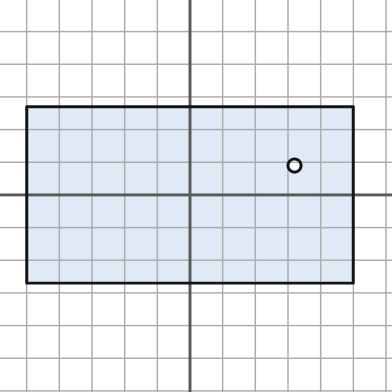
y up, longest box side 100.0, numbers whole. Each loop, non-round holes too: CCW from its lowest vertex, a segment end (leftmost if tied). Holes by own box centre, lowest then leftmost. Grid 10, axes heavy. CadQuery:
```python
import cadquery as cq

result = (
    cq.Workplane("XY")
    .moveTo(-50.0, -27.0)
    .lineTo(50.0, -27.0)
    .lineTo(50.0, 27.0)
    .lineTo(-50.0, 27.0)
    .close()
    .moveTo(32.0, 9.0)
    .circle(2.0)
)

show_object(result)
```